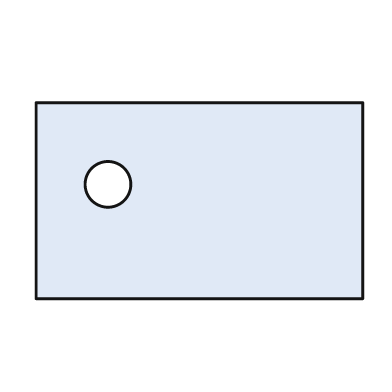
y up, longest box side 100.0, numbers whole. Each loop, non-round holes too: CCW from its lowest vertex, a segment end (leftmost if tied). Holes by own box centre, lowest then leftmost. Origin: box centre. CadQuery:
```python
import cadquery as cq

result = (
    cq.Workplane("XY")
    .moveTo(-50.0, -30.0)
    .lineTo(50.0, -30.0)
    .lineTo(50.0, 30.0)
    .lineTo(-50.0, 30.0)
    .close()
    .moveTo(-28.0, 5.0)
    .circle(7.0)
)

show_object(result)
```